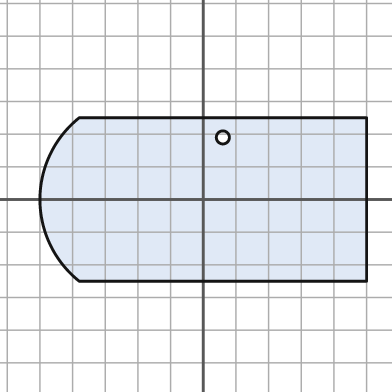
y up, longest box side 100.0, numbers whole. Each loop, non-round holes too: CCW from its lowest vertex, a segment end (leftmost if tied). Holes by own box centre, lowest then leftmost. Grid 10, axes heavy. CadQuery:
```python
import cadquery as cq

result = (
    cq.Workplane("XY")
    .moveTo(-38.0, -25.0)
    .lineTo(50.0, -25.0)
    .lineTo(50.0, 25.0)
    .lineTo(-38.0, 25.0)
    .threePointArc((-50.0, 0.0), (-38.0, -25.0))
    .close()
    .moveTo(6.0, 19.0)
    .circle(2.0)
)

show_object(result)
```